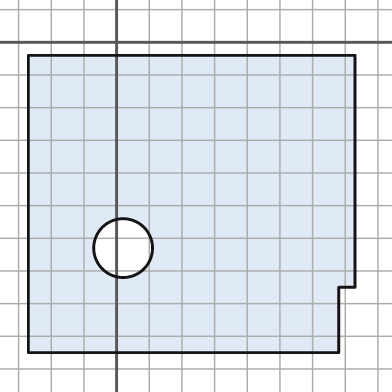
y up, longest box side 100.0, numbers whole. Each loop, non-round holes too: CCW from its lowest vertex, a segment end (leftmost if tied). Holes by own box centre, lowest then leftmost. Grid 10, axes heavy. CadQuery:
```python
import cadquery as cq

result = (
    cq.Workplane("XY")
    .moveTo(-27.0, -95.0)
    .lineTo(68.0, -95.0)
    .lineTo(68.0, -75.0)
    .lineTo(73.0, -75.0)
    .lineTo(73.0, -4.0)
    .lineTo(-27.0, -4.0)
    .close()
    .moveTo(2.0, -63.0)
    .circle(9.0)
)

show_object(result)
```